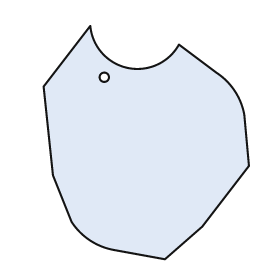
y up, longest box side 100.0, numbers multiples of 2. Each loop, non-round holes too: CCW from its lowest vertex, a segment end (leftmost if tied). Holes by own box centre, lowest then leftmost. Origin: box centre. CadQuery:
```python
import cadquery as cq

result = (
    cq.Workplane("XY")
    .moveTo(8.0, -50.0)
    .lineTo(24.0, -36.0)
    .lineTo(44.0, -10.0)
    .lineTo(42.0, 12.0)
    .threePointArc((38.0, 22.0), (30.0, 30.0))
    .lineTo(14.0, 42.0)
    .threePointArc((-8.0, 32.0), (-24.0, 50.0))
    .lineTo(-44.0, 24.0)
    .lineTo(-40.0, -14.0)
    .lineTo(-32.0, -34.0)
    .threePointArc((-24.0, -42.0), (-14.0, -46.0))
    .close()
    .moveTo(-18.0, 28.0)
    .circle(2.0)
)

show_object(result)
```